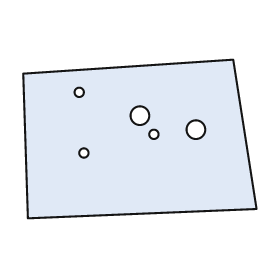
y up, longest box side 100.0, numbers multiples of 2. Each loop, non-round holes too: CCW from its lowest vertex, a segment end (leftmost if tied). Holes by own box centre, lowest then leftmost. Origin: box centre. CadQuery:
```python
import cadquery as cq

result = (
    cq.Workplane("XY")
    .moveTo(-48.0, -34.0)
    .lineTo(50.0, -30.0)
    .lineTo(40.0, 34.0)
    .lineTo(-50.0, 28.0)
    .close()
    .moveTo(-24.0, -6.0)
    .circle(2.0)
    .moveTo(6.0, 2.0)
    .circle(2.0)
    .moveTo(24.0, 4.0)
    .circle(4.0)
    .moveTo(0.0, 10.0)
    .circle(4.0)
    .moveTo(-26.0, 20.0)
    .circle(2.0)
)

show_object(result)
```